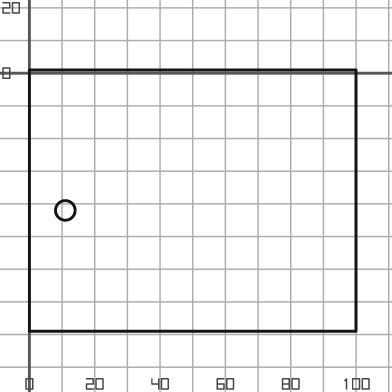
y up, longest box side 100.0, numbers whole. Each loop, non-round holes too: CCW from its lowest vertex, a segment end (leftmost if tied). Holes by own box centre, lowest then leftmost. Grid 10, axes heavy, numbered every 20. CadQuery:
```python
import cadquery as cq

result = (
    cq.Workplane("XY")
    .moveTo(0.0, -79.0)
    .lineTo(100.0, -79.0)
    .lineTo(100.0, 1.0)
    .lineTo(0.0, 1.0)
    .close()
    .moveTo(11.0, -42.0)
    .circle(3.0)
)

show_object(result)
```